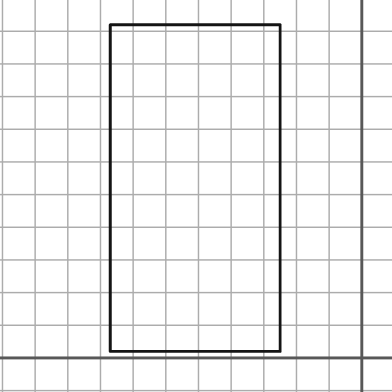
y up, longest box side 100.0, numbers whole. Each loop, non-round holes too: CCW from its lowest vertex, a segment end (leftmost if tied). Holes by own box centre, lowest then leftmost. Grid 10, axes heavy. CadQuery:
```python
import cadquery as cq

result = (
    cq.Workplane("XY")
    .moveTo(-77.0, 2.0)
    .lineTo(-25.0, 2.0)
    .lineTo(-25.0, 102.0)
    .lineTo(-77.0, 102.0)
    .close()
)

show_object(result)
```